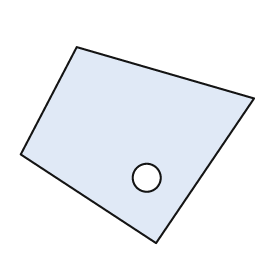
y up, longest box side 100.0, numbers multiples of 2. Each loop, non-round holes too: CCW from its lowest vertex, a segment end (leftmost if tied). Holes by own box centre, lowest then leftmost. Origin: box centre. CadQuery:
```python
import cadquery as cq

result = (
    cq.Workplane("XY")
    .moveTo(8.0, -42.0)
    .lineTo(50.0, 20.0)
    .lineTo(-26.0, 42.0)
    .lineTo(-50.0, -4.0)
    .close()
    .moveTo(4.0, -14.0)
    .circle(6.0)
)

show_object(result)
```